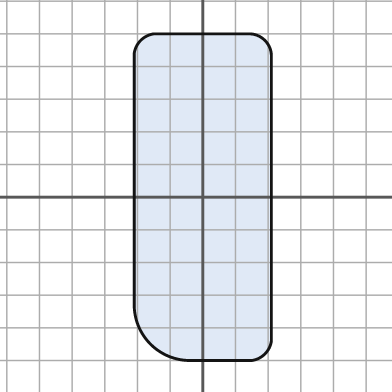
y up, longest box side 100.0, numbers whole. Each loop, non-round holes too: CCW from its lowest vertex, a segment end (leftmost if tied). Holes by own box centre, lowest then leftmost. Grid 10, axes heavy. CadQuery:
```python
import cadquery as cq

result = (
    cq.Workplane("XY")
    .moveTo(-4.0, -50.0)
    .lineTo(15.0, -50.0)
    .threePointArc((19.0, -48.0), (21.0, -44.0))
    .lineTo(21.0, 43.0)
    .threePointArc((19.0, 48.0), (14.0, 50.0))
    .lineTo(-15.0, 50.0)
    .threePointArc((-19.0, 48.0), (-21.0, 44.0))
    .lineTo(-21.0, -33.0)
    .threePointArc((-16.0, -45.0), (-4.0, -50.0))
    .close()
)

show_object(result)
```